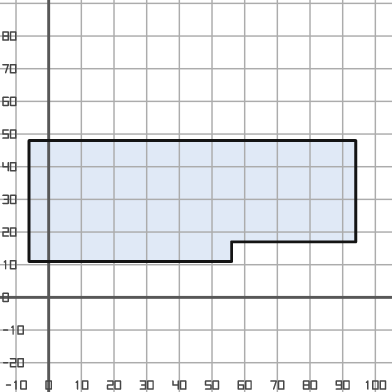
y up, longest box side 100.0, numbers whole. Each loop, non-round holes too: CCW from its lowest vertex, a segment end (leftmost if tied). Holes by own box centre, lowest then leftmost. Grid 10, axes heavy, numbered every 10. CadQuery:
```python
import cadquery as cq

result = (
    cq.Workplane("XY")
    .moveTo(-6.0, 11.0)
    .lineTo(56.0, 11.0)
    .lineTo(56.0, 17.0)
    .lineTo(94.0, 17.0)
    .lineTo(94.0, 48.0)
    .lineTo(-6.0, 48.0)
    .close()
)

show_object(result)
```